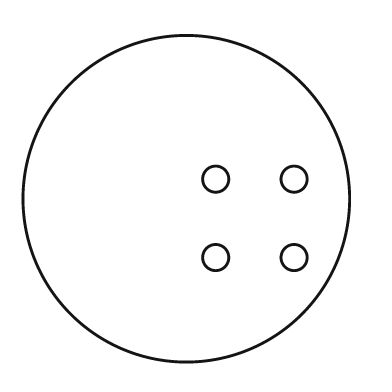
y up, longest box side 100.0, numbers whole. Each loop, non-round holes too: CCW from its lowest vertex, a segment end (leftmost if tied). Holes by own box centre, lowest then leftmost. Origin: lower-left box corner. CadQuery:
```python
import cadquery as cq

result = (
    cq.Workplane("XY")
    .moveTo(50.0, 50.0)
    .circle(50.0)
    .moveTo(59.0, 32.0)
    .circle(4.0)
    .moveTo(83.0, 32.0)
    .circle(4.0)
    .moveTo(59.0, 56.0)
    .circle(4.0)
    .moveTo(83.0, 56.0)
    .circle(4.0)
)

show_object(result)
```